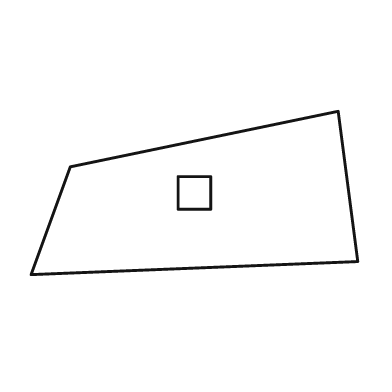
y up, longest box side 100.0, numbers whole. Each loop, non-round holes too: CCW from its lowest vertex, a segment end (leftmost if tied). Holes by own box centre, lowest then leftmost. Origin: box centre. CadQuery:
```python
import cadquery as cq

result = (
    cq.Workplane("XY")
    .moveTo(-50.0, -25.0)
    .lineTo(50.0, -21.0)
    .lineTo(44.0, 25.0)
    .lineTo(-38.0, 8.0)
    .close()
    .moveTo(-5.0, -5.0)
    .lineTo(5.0, -5.0)
    .lineTo(5.0, 5.0)
    .lineTo(-5.0, 5.0)
    .close()
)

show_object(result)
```